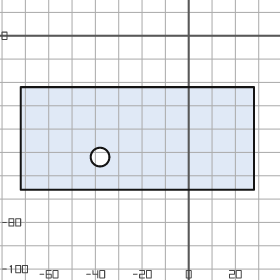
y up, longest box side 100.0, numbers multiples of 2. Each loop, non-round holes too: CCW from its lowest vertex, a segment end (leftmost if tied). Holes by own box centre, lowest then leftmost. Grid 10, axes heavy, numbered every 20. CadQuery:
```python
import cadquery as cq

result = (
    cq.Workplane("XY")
    .moveTo(-72.0, -66.0)
    .lineTo(28.0, -66.0)
    .lineTo(28.0, -22.0)
    .lineTo(-72.0, -22.0)
    .close()
    .moveTo(-38.0, -52.0)
    .circle(4.0)
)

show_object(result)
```